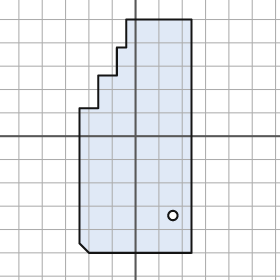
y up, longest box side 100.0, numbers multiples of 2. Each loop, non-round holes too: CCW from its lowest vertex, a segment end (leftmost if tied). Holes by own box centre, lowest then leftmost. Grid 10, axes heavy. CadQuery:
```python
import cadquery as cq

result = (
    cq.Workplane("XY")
    .moveTo(-20.0, -50.0)
    .lineTo(24.0, -50.0)
    .lineTo(24.0, 50.0)
    .lineTo(-4.0, 50.0)
    .lineTo(-4.0, 38.0)
    .lineTo(-8.0, 38.0)
    .lineTo(-8.0, 26.0)
    .lineTo(-16.0, 26.0)
    .lineTo(-16.0, 12.0)
    .lineTo(-24.0, 12.0)
    .lineTo(-24.0, -46.0)
    .close()
    .moveTo(16.0, -34.0)
    .circle(2.0)
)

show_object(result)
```